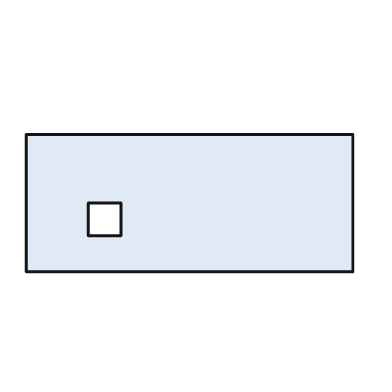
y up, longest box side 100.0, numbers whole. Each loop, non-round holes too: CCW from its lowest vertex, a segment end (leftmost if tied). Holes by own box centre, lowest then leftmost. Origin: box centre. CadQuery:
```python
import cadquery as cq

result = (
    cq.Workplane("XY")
    .moveTo(-50.0, -21.0)
    .lineTo(50.0, -21.0)
    .lineTo(50.0, 21.0)
    .lineTo(-50.0, 21.0)
    .close()
    .moveTo(-31.0, -10.0)
    .lineTo(-21.0, -10.0)
    .lineTo(-21.0, 0.0)
    .lineTo(-31.0, 0.0)
    .close()
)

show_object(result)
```